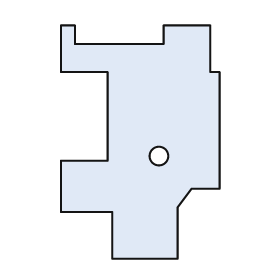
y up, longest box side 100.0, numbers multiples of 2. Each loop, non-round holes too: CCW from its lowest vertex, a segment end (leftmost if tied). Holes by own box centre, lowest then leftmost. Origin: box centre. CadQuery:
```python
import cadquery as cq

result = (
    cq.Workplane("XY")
    .moveTo(-12.0, -50.0)
    .lineTo(16.0, -50.0)
    .lineTo(16.0, -28.0)
    .lineTo(22.0, -20.0)
    .lineTo(34.0, -20.0)
    .lineTo(34.0, 30.0)
    .lineTo(30.0, 30.0)
    .lineTo(30.0, 50.0)
    .lineTo(10.0, 50.0)
    .lineTo(10.0, 42.0)
    .lineTo(-28.0, 42.0)
    .lineTo(-28.0, 50.0)
    .lineTo(-34.0, 50.0)
    .lineTo(-34.0, 30.0)
    .lineTo(-14.0, 30.0)
    .lineTo(-14.0, -8.0)
    .lineTo(-34.0, -8.0)
    .lineTo(-34.0, -30.0)
    .lineTo(-12.0, -30.0)
    .close()
    .moveTo(8.0, -6.0)
    .circle(4.0)
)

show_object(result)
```